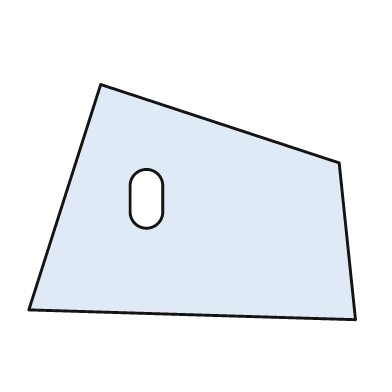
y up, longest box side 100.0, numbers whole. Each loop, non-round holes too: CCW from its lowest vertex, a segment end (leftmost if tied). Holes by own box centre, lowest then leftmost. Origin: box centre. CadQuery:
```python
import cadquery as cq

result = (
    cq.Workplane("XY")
    .moveTo(50.0, -36.0)
    .lineTo(45.0, 12.0)
    .lineTo(-28.0, 36.0)
    .lineTo(-50.0, -33.0)
    .close()
    .moveTo(-19.0, -3.0)
    .threePointArc((-14.0, -8.0), (-9.0, -3.0))
    .lineTo(-9.0, 5.0)
    .threePointArc((-14.0, 10.0), (-19.0, 5.0))
    .close()
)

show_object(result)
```